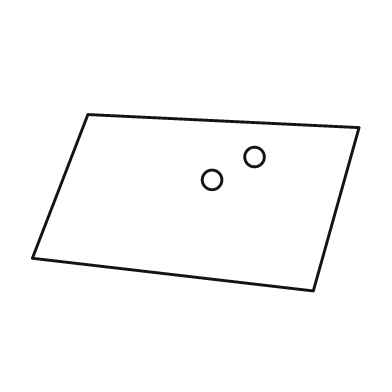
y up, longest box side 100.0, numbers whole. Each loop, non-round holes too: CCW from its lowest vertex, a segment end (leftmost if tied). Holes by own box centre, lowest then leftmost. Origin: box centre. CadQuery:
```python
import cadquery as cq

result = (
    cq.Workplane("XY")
    .moveTo(36.0, -27.0)
    .lineTo(50.0, 23.0)
    .lineTo(-33.0, 27.0)
    .lineTo(-50.0, -17.0)
    .close()
    .moveTo(5.0, 7.0)
    .circle(3.0)
    .moveTo(18.0, 14.0)
    .circle(3.0)
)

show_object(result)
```